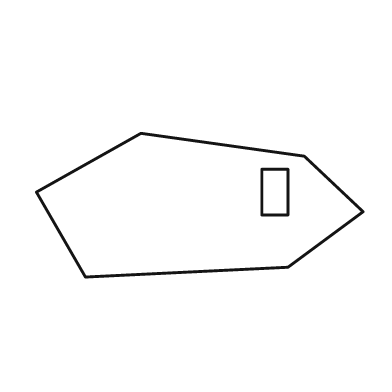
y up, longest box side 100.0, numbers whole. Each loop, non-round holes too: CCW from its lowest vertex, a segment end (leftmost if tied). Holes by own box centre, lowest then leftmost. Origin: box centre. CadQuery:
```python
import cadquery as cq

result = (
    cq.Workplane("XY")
    .moveTo(-35.0, -22.0)
    .lineTo(27.0, -19.0)
    .lineTo(50.0, -2.0)
    .lineTo(32.0, 15.0)
    .lineTo(-18.0, 22.0)
    .lineTo(-50.0, 4.0)
    .close()
    .moveTo(19.0, -3.0)
    .lineTo(27.0, -3.0)
    .lineTo(27.0, 11.0)
    .lineTo(19.0, 11.0)
    .close()
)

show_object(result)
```